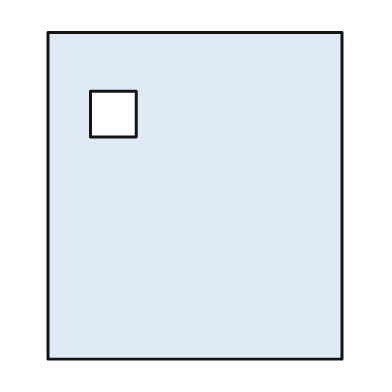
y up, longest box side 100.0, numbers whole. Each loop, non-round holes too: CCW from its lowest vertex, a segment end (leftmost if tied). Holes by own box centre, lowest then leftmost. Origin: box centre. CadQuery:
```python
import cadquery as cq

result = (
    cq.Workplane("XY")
    .moveTo(-45.0, -50.0)
    .lineTo(45.0, -50.0)
    .lineTo(45.0, 50.0)
    .lineTo(-45.0, 50.0)
    .close()
    .moveTo(-32.0, 18.0)
    .lineTo(-18.0, 18.0)
    .lineTo(-18.0, 32.0)
    .lineTo(-32.0, 32.0)
    .close()
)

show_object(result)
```